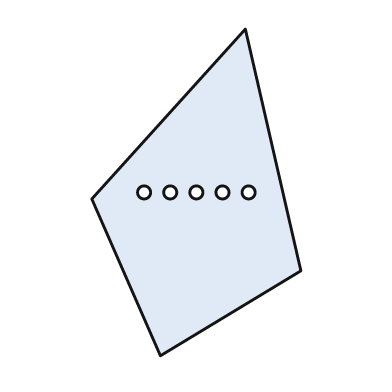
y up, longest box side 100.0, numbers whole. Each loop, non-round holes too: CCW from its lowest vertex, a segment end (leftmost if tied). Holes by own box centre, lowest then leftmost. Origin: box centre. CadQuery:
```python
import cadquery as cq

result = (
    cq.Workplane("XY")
    .moveTo(-11.0, -50.0)
    .lineTo(32.0, -24.0)
    .lineTo(15.0, 50.0)
    .lineTo(-32.0, -2.0)
    .close()
    .moveTo(-16.0, 0.0)
    .circle(2.0)
    .moveTo(-8.0, 0.0)
    .circle(2.0)
    .moveTo(0.0, 0.0)
    .circle(2.0)
    .moveTo(8.0, 0.0)
    .circle(2.0)
    .moveTo(16.0, 0.0)
    .circle(2.0)
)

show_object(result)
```